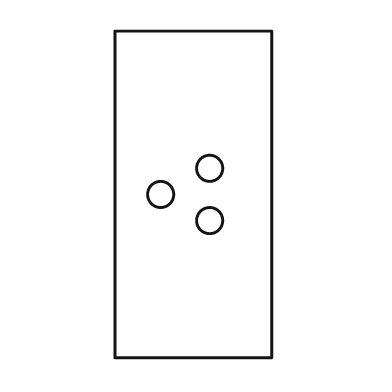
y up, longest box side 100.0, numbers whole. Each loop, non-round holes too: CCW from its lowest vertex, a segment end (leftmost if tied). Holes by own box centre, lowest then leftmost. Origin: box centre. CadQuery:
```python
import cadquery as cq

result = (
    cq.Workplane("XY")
    .moveTo(-24.0, -50.0)
    .lineTo(24.0, -50.0)
    .lineTo(24.0, 50.0)
    .lineTo(-24.0, 50.0)
    .close()
    .moveTo(5.0, -8.0)
    .circle(4.0)
    .moveTo(-10.0, 0.0)
    .circle(4.0)
    .moveTo(5.0, 8.0)
    .circle(4.0)
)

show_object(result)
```